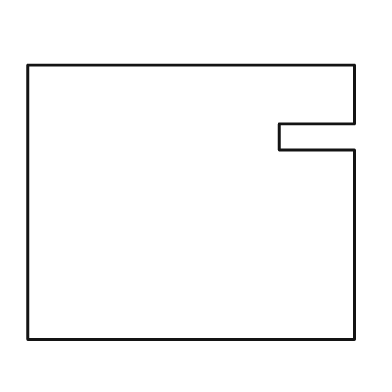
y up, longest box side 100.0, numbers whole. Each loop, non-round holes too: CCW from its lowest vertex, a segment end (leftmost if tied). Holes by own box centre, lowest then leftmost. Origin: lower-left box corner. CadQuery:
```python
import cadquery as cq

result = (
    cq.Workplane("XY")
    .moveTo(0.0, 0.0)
    .lineTo(100.0, 0.0)
    .lineTo(100.0, 58.0)
    .lineTo(77.0, 58.0)
    .lineTo(77.0, 66.0)
    .lineTo(100.0, 66.0)
    .lineTo(100.0, 84.0)
    .lineTo(0.0, 84.0)
    .close()
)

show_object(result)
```